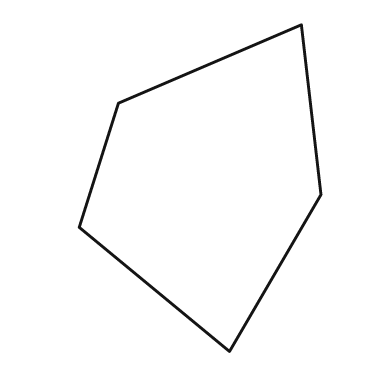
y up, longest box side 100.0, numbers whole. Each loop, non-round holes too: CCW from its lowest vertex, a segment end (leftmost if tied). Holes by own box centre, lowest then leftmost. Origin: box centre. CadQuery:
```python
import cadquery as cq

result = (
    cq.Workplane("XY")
    .moveTo(9.0, -50.0)
    .lineTo(37.0, -2.0)
    .lineTo(31.0, 50.0)
    .lineTo(-25.0, 26.0)
    .lineTo(-37.0, -12.0)
    .close()
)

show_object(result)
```